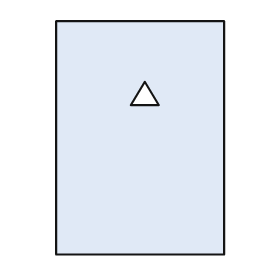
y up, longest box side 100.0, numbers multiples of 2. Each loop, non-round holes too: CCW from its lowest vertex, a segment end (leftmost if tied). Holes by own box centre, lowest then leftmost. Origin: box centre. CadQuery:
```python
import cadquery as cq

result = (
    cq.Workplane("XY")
    .moveTo(-36.0, -50.0)
    .lineTo(36.0, -50.0)
    .lineTo(36.0, 50.0)
    .lineTo(-36.0, 50.0)
    .close()
    .moveTo(-4.0, 14.0)
    .lineTo(8.0, 14.0)
    .lineTo(2.0, 24.0)
    .close()
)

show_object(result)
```